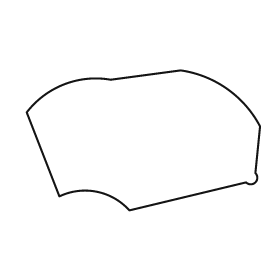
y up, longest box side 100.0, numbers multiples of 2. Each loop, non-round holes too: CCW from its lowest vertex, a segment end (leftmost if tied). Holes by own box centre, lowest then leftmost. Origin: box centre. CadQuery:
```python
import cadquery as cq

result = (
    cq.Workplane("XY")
    .moveTo(-6.0, -30.0)
    .lineTo(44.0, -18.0)
    .threePointArc((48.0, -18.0), (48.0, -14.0))
    .lineTo(50.0, 6.0)
    .threePointArc((36.0, 22.0), (16.0, 30.0))
    .lineTo(-14.0, 26.0)
    .threePointArc((-34.0, 24.0), (-50.0, 12.0))
    .lineTo(-36.0, -24.0)
    .threePointArc((-20.0, -22.0), (-6.0, -30.0))
    .close()
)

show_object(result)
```